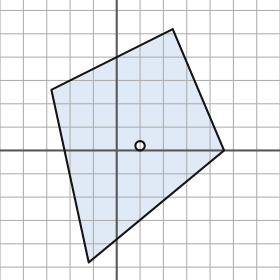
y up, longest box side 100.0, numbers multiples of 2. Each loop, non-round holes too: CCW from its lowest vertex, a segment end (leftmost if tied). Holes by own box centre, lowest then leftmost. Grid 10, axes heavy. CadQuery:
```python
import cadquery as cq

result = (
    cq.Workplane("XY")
    .moveTo(-12.0, -48.0)
    .lineTo(46.0, 0.0)
    .lineTo(24.0, 52.0)
    .lineTo(-28.0, 26.0)
    .close()
    .moveTo(10.0, 2.0)
    .circle(2.0)
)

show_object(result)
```